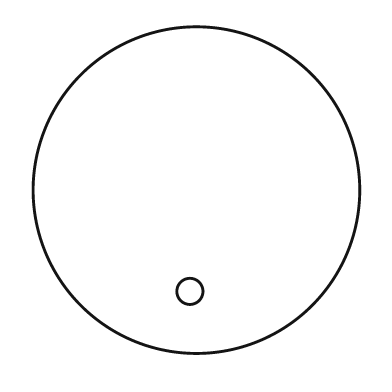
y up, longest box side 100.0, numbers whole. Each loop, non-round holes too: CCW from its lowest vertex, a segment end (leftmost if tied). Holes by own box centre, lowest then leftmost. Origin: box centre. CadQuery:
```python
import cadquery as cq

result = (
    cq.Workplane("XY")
    .moveTo(0.0, 0.0)
    .circle(50.0)
    .moveTo(-2.0, -31.0)
    .circle(4.0)
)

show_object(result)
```